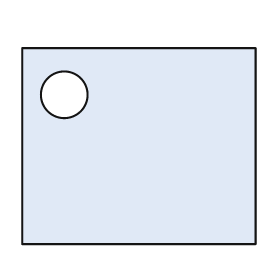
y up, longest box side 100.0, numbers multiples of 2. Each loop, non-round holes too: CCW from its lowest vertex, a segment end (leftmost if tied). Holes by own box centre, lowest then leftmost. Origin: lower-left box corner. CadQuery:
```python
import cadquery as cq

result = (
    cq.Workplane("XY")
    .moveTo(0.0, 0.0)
    .lineTo(100.0, 0.0)
    .lineTo(100.0, 84.0)
    .lineTo(0.0, 84.0)
    .close()
    .moveTo(18.0, 64.0)
    .circle(10.0)
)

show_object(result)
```